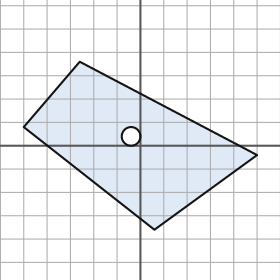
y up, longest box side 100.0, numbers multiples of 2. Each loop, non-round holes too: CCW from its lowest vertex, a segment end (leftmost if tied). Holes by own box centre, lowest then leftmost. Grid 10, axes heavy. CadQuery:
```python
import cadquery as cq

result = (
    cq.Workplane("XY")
    .moveTo(6.0, -36.0)
    .lineTo(50.0, -4.0)
    .lineTo(-26.0, 36.0)
    .lineTo(-50.0, 8.0)
    .close()
    .moveTo(-4.0, 4.0)
    .circle(4.0)
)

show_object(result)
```